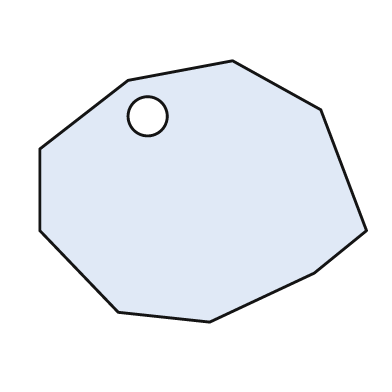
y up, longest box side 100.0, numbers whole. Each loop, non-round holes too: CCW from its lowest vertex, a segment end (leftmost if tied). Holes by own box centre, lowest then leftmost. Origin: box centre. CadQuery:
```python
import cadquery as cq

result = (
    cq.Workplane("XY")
    .moveTo(2.0, -40.0)
    .lineTo(34.0, -25.0)
    .lineTo(50.0, -12.0)
    .lineTo(36.0, 25.0)
    .lineTo(9.0, 40.0)
    .lineTo(-23.0, 34.0)
    .lineTo(-50.0, 13.0)
    .lineTo(-50.0, -12.0)
    .lineTo(-26.0, -37.0)
    .close()
    .moveTo(-17.0, 23.0)
    .circle(6.0)
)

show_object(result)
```